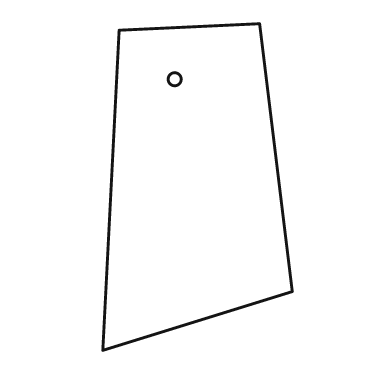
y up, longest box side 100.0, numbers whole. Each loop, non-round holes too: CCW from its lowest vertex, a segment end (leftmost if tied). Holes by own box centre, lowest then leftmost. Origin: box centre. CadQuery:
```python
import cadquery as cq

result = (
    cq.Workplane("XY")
    .moveTo(-29.0, -50.0)
    .lineTo(29.0, -32.0)
    .lineTo(19.0, 50.0)
    .lineTo(-24.0, 48.0)
    .close()
    .moveTo(-7.0, 33.0)
    .circle(2.0)
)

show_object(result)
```